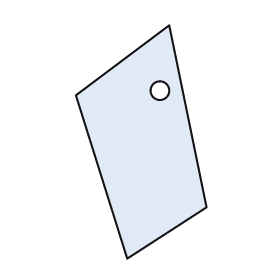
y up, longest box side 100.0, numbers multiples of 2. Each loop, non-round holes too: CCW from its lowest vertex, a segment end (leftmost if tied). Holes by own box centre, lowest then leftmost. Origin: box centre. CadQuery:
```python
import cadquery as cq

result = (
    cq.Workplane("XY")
    .moveTo(-6.0, -50.0)
    .lineTo(28.0, -28.0)
    .lineTo(12.0, 50.0)
    .lineTo(-28.0, 20.0)
    .close()
    .moveTo(8.0, 22.0)
    .circle(4.0)
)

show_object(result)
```